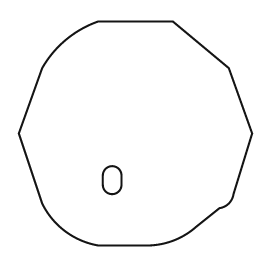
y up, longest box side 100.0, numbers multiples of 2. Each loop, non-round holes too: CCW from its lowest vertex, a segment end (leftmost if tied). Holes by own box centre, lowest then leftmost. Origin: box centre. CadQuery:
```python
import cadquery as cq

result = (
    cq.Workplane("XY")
    .moveTo(-16.0, -48.0)
    .lineTo(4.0, -48.0)
    .threePointArc((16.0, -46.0), (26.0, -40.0))
    .lineTo(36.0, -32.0)
    .threePointArc((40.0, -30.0), (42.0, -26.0))
    .lineTo(50.0, 0.0)
    .lineTo(40.0, 28.0)
    .lineTo(16.0, 48.0)
    .lineTo(-16.0, 48.0)
    .threePointArc((-30.0, 40.0), (-40.0, 28.0))
    .lineTo(-50.0, 0.0)
    .lineTo(-40.0, -30.0)
    .threePointArc((-30.0, -42.0), (-16.0, -48.0))
    .close()
    .moveTo(-14.0, -22.0)
    .threePointArc((-10.0, -26.0), (-6.0, -22.0))
    .lineTo(-6.0, -18.0)
    .threePointArc((-10.0, -14.0), (-14.0, -18.0))
    .close()
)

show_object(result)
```